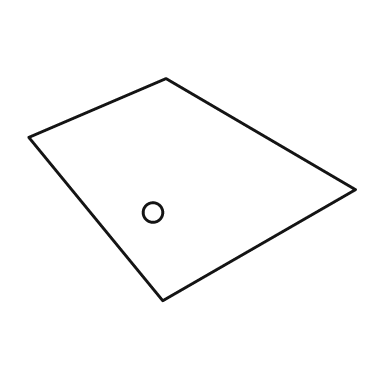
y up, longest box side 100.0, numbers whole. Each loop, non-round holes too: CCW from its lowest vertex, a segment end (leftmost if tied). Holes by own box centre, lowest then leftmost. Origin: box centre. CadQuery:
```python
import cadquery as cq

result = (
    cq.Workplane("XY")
    .moveTo(-9.0, -34.0)
    .lineTo(50.0, 0.0)
    .lineTo(-8.0, 34.0)
    .lineTo(-50.0, 16.0)
    .close()
    .moveTo(-12.0, -7.0)
    .circle(3.0)
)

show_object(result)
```